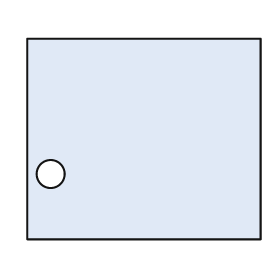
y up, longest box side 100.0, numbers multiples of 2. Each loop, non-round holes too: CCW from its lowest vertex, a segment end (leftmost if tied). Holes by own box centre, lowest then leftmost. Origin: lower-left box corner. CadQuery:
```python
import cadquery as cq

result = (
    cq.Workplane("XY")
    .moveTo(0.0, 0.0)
    .lineTo(100.0, 0.0)
    .lineTo(100.0, 86.0)
    .lineTo(0.0, 86.0)
    .close()
    .moveTo(10.0, 28.0)
    .circle(6.0)
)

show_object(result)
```